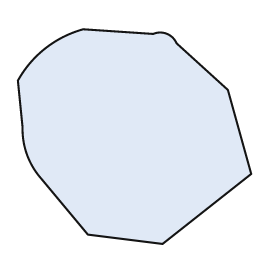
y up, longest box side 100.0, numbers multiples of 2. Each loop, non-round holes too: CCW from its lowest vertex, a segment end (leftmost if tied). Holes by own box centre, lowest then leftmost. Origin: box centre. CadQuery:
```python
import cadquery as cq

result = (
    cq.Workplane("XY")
    .moveTo(12.0, -46.0)
    .lineTo(50.0, -16.0)
    .lineTo(40.0, 20.0)
    .lineTo(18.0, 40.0)
    .threePointArc((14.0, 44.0), (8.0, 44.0))
    .lineTo(-22.0, 46.0)
    .threePointArc((-38.0, 38.0), (-50.0, 24.0))
    .lineTo(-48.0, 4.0)
    .threePointArc((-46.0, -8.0), (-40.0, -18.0))
    .lineTo(-20.0, -42.0)
    .close()
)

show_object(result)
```